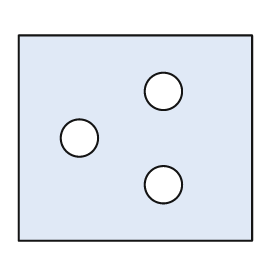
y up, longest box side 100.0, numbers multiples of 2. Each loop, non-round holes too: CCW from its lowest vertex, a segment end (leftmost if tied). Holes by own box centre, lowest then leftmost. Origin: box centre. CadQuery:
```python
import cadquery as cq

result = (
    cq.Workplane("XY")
    .moveTo(-50.0, -44.0)
    .lineTo(50.0, -44.0)
    .lineTo(50.0, 44.0)
    .lineTo(-50.0, 44.0)
    .close()
    .moveTo(12.0, -20.0)
    .circle(8.0)
    .moveTo(-24.0, 0.0)
    .circle(8.0)
    .moveTo(12.0, 20.0)
    .circle(8.0)
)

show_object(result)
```